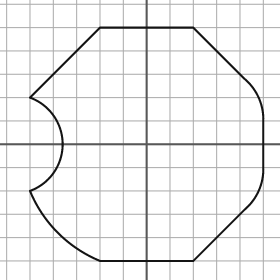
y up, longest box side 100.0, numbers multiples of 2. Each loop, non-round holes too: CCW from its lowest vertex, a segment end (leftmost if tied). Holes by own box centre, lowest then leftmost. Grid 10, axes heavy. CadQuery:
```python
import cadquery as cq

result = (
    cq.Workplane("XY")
    .moveTo(-20.0, -50.0)
    .lineTo(20.0, -50.0)
    .lineTo(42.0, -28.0)
    .threePointArc((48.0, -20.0), (50.0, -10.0))
    .lineTo(50.0, 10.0)
    .threePointArc((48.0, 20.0), (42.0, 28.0))
    .lineTo(20.0, 50.0)
    .lineTo(-20.0, 50.0)
    .lineTo(-50.0, 20.0)
    .threePointArc((-36.0, 0.0), (-50.0, -20.0))
    .threePointArc((-38.0, -38.0), (-20.0, -50.0))
    .close()
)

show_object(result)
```